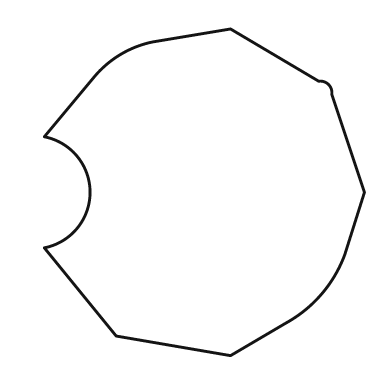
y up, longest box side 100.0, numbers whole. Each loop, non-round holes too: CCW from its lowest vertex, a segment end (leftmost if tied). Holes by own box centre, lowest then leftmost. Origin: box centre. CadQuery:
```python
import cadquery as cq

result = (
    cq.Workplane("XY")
    .moveTo(8.0, -50.0)
    .lineTo(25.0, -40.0)
    .threePointArc((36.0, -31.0), (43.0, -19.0))
    .lineTo(49.0, 0.0)
    .lineTo(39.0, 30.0)
    .threePointArc((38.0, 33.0), (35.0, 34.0))
    .lineTo(8.0, 50.0)
    .lineTo(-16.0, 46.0)
    .threePointArc((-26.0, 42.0), (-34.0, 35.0))
    .lineTo(-49.0, 17.0)
    .threePointArc((-35.0, 0.0), (-49.0, -17.0))
    .lineTo(-27.0, -44.0)
    .close()
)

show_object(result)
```